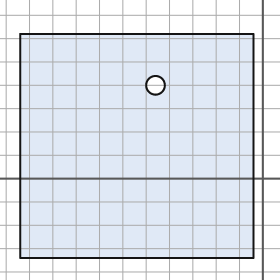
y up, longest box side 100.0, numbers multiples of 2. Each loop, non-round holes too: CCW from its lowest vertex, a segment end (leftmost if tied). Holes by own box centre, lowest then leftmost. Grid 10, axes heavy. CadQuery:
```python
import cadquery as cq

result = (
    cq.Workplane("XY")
    .moveTo(-104.0, -34.0)
    .lineTo(-4.0, -34.0)
    .lineTo(-4.0, 62.0)
    .lineTo(-104.0, 62.0)
    .close()
    .moveTo(-46.0, 40.0)
    .circle(4.0)
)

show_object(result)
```